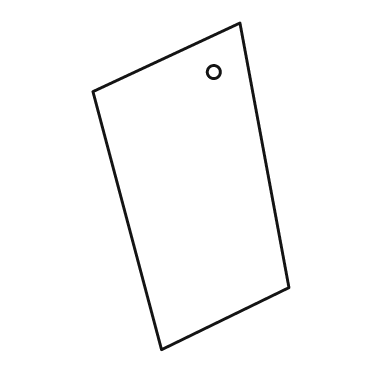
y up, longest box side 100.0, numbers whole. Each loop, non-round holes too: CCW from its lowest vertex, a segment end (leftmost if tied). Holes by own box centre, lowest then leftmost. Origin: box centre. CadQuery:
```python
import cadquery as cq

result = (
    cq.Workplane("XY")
    .moveTo(-9.0, -50.0)
    .lineTo(30.0, -31.0)
    .lineTo(15.0, 50.0)
    .lineTo(-30.0, 29.0)
    .close()
    .moveTo(7.0, 35.0)
    .circle(2.0)
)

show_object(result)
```